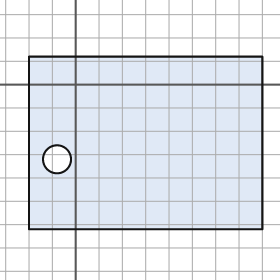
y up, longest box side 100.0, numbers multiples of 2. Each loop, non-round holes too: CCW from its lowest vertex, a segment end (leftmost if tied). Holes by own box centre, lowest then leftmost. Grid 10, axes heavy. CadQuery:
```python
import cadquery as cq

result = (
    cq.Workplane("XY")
    .moveTo(-20.0, -62.0)
    .lineTo(80.0, -62.0)
    .lineTo(80.0, 12.0)
    .lineTo(-20.0, 12.0)
    .close()
    .moveTo(-8.0, -32.0)
    .circle(6.0)
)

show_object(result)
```